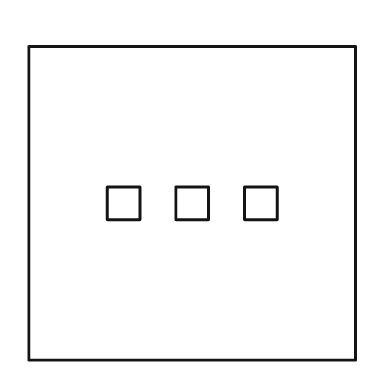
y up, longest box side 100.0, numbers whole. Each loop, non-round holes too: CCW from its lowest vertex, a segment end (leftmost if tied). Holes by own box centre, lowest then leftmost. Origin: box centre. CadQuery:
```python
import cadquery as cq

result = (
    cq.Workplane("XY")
    .moveTo(-50.0, -48.0)
    .lineTo(50.0, -48.0)
    .lineTo(50.0, 48.0)
    .lineTo(-50.0, 48.0)
    .close()
    .moveTo(-26.0, -5.0)
    .lineTo(-16.0, -5.0)
    .lineTo(-16.0, 5.0)
    .lineTo(-26.0, 5.0)
    .close()
    .moveTo(-5.0, -5.0)
    .lineTo(5.0, -5.0)
    .lineTo(5.0, 5.0)
    .lineTo(-5.0, 5.0)
    .close()
    .moveTo(16.0, -5.0)
    .lineTo(26.0, -5.0)
    .lineTo(26.0, 5.0)
    .lineTo(16.0, 5.0)
    .close()
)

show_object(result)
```